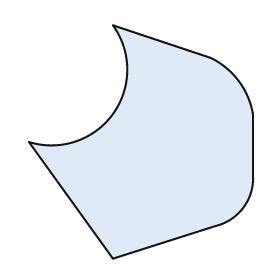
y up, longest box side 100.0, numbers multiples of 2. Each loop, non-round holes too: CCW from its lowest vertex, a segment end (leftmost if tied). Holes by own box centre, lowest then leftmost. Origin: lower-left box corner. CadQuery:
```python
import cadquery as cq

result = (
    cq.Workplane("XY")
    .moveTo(36.0, 0.0)
    .lineTo(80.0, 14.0)
    .threePointArc((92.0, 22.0), (96.0, 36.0))
    .lineTo(96.0, 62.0)
    .threePointArc((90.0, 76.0), (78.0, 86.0))
    .lineTo(36.0, 100.0)
    .threePointArc((36.0, 62.0), (0.0, 50.0))
    .close()
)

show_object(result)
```